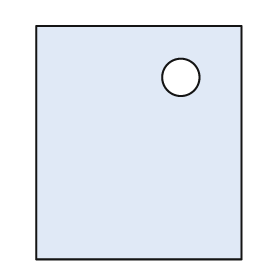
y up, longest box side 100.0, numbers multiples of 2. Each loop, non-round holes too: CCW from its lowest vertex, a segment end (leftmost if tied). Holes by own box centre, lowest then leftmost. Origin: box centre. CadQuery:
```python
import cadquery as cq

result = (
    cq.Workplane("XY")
    .moveTo(-44.0, -50.0)
    .lineTo(44.0, -50.0)
    .lineTo(44.0, 50.0)
    .lineTo(-44.0, 50.0)
    .close()
    .moveTo(18.0, 28.0)
    .circle(8.0)
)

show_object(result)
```